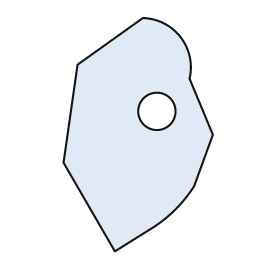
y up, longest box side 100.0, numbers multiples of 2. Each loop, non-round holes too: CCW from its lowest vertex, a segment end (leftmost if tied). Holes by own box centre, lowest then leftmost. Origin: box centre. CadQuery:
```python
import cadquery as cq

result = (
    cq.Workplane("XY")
    .moveTo(-10.0, -50.0)
    .lineTo(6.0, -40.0)
    .threePointArc((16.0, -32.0), (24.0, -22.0))
    .lineTo(32.0, 0.0)
    .lineTo(22.0, 24.0)
    .threePointArc((18.0, 42.0), (2.0, 50.0))
    .lineTo(-26.0, 30.0)
    .lineTo(-32.0, -12.0)
    .close()
    .moveTo(8.0, 10.0)
    .circle(8.0)
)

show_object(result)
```